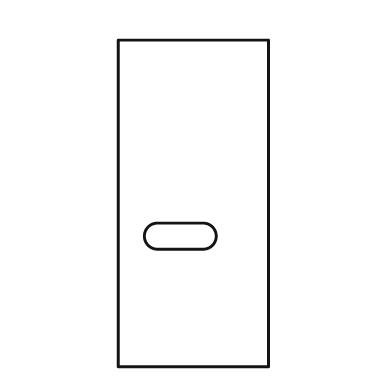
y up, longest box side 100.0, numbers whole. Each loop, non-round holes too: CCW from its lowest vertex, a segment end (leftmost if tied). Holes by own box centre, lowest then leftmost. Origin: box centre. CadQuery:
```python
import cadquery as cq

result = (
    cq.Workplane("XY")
    .moveTo(-23.0, -50.0)
    .lineTo(23.0, -50.0)
    .lineTo(23.0, 50.0)
    .lineTo(-23.0, 50.0)
    .close()
    .moveTo(-11.0, -14.0)
    .lineTo(3.0, -14.0)
    .threePointArc((7.0, -10.0), (3.0, -6.0))
    .lineTo(-11.0, -6.0)
    .threePointArc((-15.0, -10.0), (-11.0, -14.0))
    .close()
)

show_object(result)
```